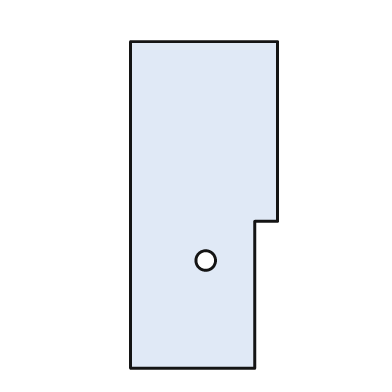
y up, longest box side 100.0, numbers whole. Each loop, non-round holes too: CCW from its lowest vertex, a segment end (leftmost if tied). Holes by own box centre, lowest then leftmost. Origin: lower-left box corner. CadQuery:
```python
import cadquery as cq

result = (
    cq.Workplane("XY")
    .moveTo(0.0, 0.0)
    .lineTo(38.0, 0.0)
    .lineTo(38.0, 45.0)
    .lineTo(45.0, 45.0)
    .lineTo(45.0, 100.0)
    .lineTo(0.0, 100.0)
    .close()
    .moveTo(23.0, 33.0)
    .circle(3.0)
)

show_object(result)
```